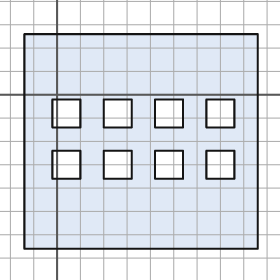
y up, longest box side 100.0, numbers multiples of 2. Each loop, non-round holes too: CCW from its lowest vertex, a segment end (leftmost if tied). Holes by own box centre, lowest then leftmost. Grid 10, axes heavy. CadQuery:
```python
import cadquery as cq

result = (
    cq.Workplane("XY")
    .moveTo(-14.0, -66.0)
    .lineTo(86.0, -66.0)
    .lineTo(86.0, 26.0)
    .lineTo(-14.0, 26.0)
    .close()
    .moveTo(-2.0, -36.0)
    .lineTo(10.0, -36.0)
    .lineTo(10.0, -24.0)
    .lineTo(-2.0, -24.0)
    .close()
    .moveTo(20.0, -36.0)
    .lineTo(32.0, -36.0)
    .lineTo(32.0, -24.0)
    .lineTo(20.0, -24.0)
    .close()
    .moveTo(42.0, -36.0)
    .lineTo(54.0, -36.0)
    .lineTo(54.0, -24.0)
    .lineTo(42.0, -24.0)
    .close()
    .moveTo(64.0, -36.0)
    .lineTo(76.0, -36.0)
    .lineTo(76.0, -24.0)
    .lineTo(64.0, -24.0)
    .close()
    .moveTo(-2.0, -14.0)
    .lineTo(10.0, -14.0)
    .lineTo(10.0, -2.0)
    .lineTo(-2.0, -2.0)
    .close()
    .moveTo(20.0, -14.0)
    .lineTo(32.0, -14.0)
    .lineTo(32.0, -2.0)
    .lineTo(20.0, -2.0)
    .close()
    .moveTo(42.0, -14.0)
    .lineTo(54.0, -14.0)
    .lineTo(54.0, -2.0)
    .lineTo(42.0, -2.0)
    .close()
    .moveTo(64.0, -14.0)
    .lineTo(76.0, -14.0)
    .lineTo(76.0, -2.0)
    .lineTo(64.0, -2.0)
    .close()
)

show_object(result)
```